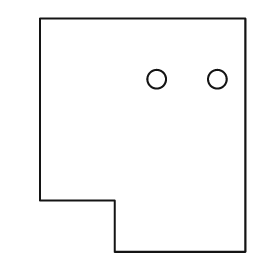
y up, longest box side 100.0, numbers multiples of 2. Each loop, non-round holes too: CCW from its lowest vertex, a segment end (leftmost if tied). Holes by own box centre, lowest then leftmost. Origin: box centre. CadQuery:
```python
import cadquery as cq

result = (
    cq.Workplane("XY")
    .moveTo(-12.0, -50.0)
    .lineTo(44.0, -50.0)
    .lineTo(44.0, 50.0)
    .lineTo(-44.0, 50.0)
    .lineTo(-44.0, -28.0)
    .lineTo(-12.0, -28.0)
    .close()
    .moveTo(6.0, 24.0)
    .circle(4.0)
    .moveTo(32.0, 24.0)
    .circle(4.0)
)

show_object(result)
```